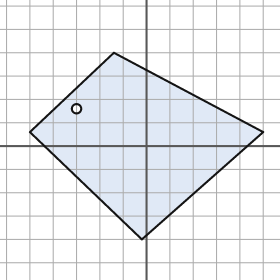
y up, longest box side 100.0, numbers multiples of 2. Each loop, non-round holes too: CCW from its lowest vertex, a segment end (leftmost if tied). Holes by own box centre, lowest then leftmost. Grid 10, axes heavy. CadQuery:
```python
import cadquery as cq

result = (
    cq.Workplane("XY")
    .moveTo(-2.0, -40.0)
    .lineTo(50.0, 6.0)
    .lineTo(-14.0, 40.0)
    .lineTo(-50.0, 6.0)
    .close()
    .moveTo(-30.0, 16.0)
    .circle(2.0)
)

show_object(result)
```